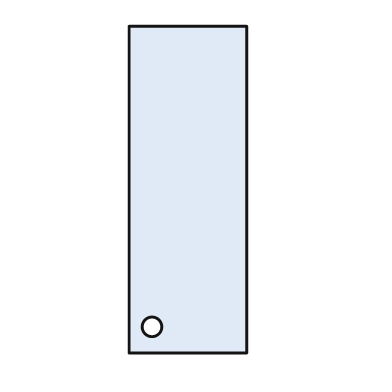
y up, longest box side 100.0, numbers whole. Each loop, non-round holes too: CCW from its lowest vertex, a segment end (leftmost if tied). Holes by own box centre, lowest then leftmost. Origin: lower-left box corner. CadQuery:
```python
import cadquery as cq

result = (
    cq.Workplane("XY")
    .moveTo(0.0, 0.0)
    .lineTo(36.0, 0.0)
    .lineTo(36.0, 100.0)
    .lineTo(0.0, 100.0)
    .close()
    .moveTo(7.0, 8.0)
    .circle(3.0)
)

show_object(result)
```